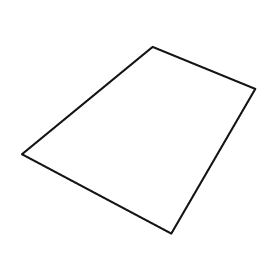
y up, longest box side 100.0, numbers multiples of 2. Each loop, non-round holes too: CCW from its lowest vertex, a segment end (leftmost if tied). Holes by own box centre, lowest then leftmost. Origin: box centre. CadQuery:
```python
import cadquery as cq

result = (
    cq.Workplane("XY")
    .moveTo(14.0, -40.0)
    .lineTo(50.0, 22.0)
    .lineTo(6.0, 40.0)
    .lineTo(-50.0, -6.0)
    .close()
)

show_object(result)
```